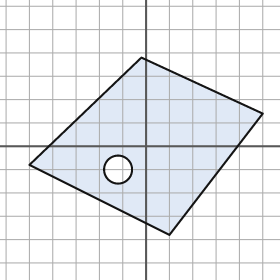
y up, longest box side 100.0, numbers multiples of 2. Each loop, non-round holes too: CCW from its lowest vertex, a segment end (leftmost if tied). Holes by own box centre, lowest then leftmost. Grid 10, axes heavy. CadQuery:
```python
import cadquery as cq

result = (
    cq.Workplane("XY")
    .moveTo(10.0, -38.0)
    .lineTo(50.0, 14.0)
    .lineTo(-2.0, 38.0)
    .lineTo(-50.0, -8.0)
    .close()
    .moveTo(-12.0, -10.0)
    .circle(6.0)
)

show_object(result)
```